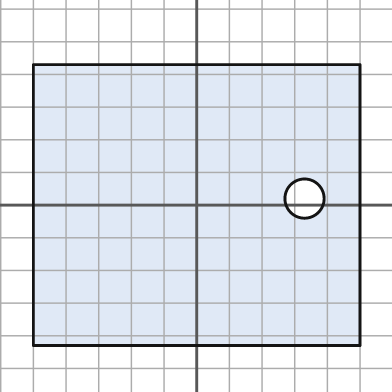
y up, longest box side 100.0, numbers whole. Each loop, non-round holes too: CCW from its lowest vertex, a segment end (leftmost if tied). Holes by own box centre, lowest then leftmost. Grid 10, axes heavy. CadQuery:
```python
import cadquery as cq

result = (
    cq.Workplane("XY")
    .moveTo(-50.0, -43.0)
    .lineTo(50.0, -43.0)
    .lineTo(50.0, 43.0)
    .lineTo(-50.0, 43.0)
    .close()
    .moveTo(33.0, 2.0)
    .circle(6.0)
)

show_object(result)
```